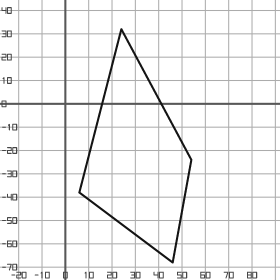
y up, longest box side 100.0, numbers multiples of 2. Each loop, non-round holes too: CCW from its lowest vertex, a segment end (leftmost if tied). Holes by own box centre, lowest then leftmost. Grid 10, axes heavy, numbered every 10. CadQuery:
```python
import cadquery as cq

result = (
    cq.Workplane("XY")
    .moveTo(46.0, -68.0)
    .lineTo(54.0, -24.0)
    .lineTo(24.0, 32.0)
    .lineTo(6.0, -38.0)
    .close()
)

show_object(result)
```